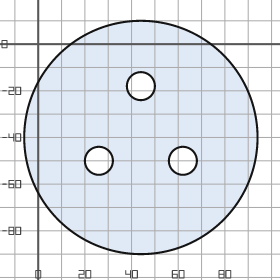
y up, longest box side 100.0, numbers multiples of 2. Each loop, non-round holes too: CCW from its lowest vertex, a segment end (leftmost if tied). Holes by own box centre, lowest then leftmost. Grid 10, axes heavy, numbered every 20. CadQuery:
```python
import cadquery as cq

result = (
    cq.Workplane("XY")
    .moveTo(44.0, -40.0)
    .circle(50.0)
    .moveTo(26.0, -50.0)
    .circle(6.0)
    .moveTo(62.0, -50.0)
    .circle(6.0)
    .moveTo(44.0, -18.0)
    .circle(6.0)
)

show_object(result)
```